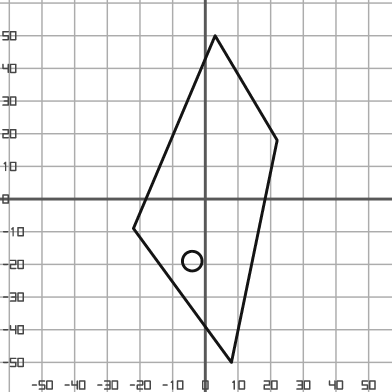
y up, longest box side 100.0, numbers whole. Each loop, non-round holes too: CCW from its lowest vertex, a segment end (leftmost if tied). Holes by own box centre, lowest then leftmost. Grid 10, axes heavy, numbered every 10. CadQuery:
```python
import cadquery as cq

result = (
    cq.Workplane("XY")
    .moveTo(8.0, -50.0)
    .lineTo(22.0, 18.0)
    .lineTo(3.0, 50.0)
    .lineTo(-22.0, -9.0)
    .close()
    .moveTo(-4.0, -19.0)
    .circle(3.0)
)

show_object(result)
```